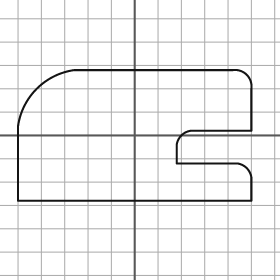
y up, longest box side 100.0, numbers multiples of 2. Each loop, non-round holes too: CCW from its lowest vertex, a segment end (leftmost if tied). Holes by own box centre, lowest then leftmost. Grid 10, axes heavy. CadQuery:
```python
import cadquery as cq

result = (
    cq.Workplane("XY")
    .moveTo(-50.0, -28.0)
    .lineTo(50.0, -28.0)
    .lineTo(50.0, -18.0)
    .threePointArc((48.0, -14.0), (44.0, -12.0))
    .lineTo(18.0, -12.0)
    .lineTo(18.0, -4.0)
    .threePointArc((20.0, 0.0), (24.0, 2.0))
    .lineTo(50.0, 2.0)
    .lineTo(50.0, 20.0)
    .threePointArc((48.0, 26.0), (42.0, 28.0))
    .lineTo(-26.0, 28.0)
    .threePointArc((-42.0, 20.0), (-50.0, 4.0))
    .close()
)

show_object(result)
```